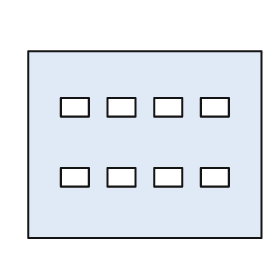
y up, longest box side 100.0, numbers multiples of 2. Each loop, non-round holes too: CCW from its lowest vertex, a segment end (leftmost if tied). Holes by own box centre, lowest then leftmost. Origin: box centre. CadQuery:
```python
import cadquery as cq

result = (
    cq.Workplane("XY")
    .moveTo(-50.0, -40.0)
    .lineTo(50.0, -40.0)
    .lineTo(50.0, 40.0)
    .lineTo(-50.0, 40.0)
    .close()
    .moveTo(-36.0, -18.0)
    .lineTo(-24.0, -18.0)
    .lineTo(-24.0, -10.0)
    .lineTo(-36.0, -10.0)
    .close()
    .moveTo(-16.0, -18.0)
    .lineTo(-4.0, -18.0)
    .lineTo(-4.0, -10.0)
    .lineTo(-16.0, -10.0)
    .close()
    .moveTo(4.0, -18.0)
    .lineTo(16.0, -18.0)
    .lineTo(16.0, -10.0)
    .lineTo(4.0, -10.0)
    .close()
    .moveTo(24.0, -18.0)
    .lineTo(36.0, -18.0)
    .lineTo(36.0, -10.0)
    .lineTo(24.0, -10.0)
    .close()
    .moveTo(-36.0, 12.0)
    .lineTo(-24.0, 12.0)
    .lineTo(-24.0, 20.0)
    .lineTo(-36.0, 20.0)
    .close()
    .moveTo(-16.0, 12.0)
    .lineTo(-4.0, 12.0)
    .lineTo(-4.0, 20.0)
    .lineTo(-16.0, 20.0)
    .close()
    .moveTo(4.0, 12.0)
    .lineTo(16.0, 12.0)
    .lineTo(16.0, 20.0)
    .lineTo(4.0, 20.0)
    .close()
    .moveTo(24.0, 12.0)
    .lineTo(36.0, 12.0)
    .lineTo(36.0, 20.0)
    .lineTo(24.0, 20.0)
    .close()
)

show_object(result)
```